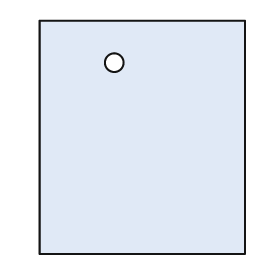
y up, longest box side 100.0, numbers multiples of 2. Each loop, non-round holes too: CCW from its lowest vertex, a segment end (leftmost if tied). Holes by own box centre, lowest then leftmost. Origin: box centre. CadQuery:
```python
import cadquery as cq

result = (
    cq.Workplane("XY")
    .moveTo(-44.0, -50.0)
    .lineTo(44.0, -50.0)
    .lineTo(44.0, 50.0)
    .lineTo(-44.0, 50.0)
    .close()
    .moveTo(-12.0, 32.0)
    .circle(4.0)
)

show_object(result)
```